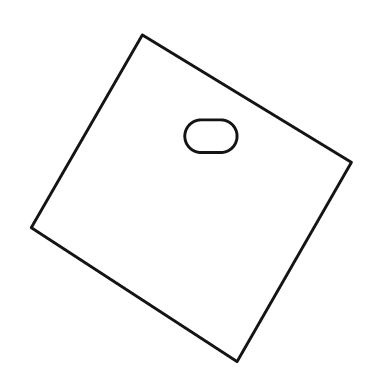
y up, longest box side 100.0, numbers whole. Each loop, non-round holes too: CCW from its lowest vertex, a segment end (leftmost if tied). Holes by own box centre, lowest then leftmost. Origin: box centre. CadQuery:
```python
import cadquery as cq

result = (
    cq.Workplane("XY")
    .moveTo(14.0, -50.0)
    .lineTo(49.0, 11.0)
    .lineTo(-15.0, 50.0)
    .lineTo(-49.0, -9.0)
    .close()
    .moveTo(3.0, 14.0)
    .lineTo(9.0, 14.0)
    .threePointArc((14.0, 19.0), (9.0, 24.0))
    .lineTo(3.0, 24.0)
    .threePointArc((-2.0, 19.0), (3.0, 14.0))
    .close()
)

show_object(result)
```